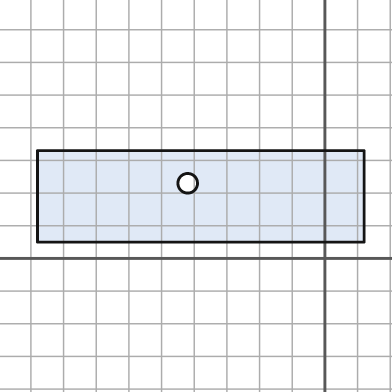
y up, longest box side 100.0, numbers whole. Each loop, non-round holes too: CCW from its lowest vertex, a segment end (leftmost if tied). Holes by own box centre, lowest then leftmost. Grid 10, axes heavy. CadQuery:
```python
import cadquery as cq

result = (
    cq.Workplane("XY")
    .moveTo(-88.0, 5.0)
    .lineTo(12.0, 5.0)
    .lineTo(12.0, 33.0)
    .lineTo(-88.0, 33.0)
    .close()
    .moveTo(-42.0, 23.0)
    .circle(3.0)
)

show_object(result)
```